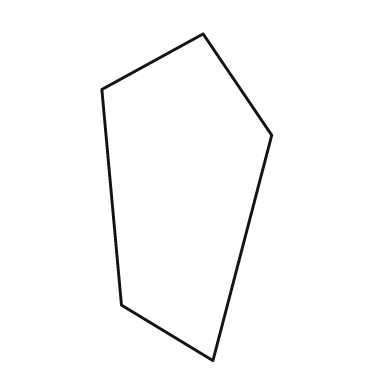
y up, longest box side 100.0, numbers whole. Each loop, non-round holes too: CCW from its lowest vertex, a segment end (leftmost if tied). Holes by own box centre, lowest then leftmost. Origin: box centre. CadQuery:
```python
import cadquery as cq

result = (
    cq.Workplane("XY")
    .moveTo(8.0, -50.0)
    .lineTo(26.0, 19.0)
    .lineTo(5.0, 50.0)
    .lineTo(-26.0, 33.0)
    .lineTo(-20.0, -33.0)
    .close()
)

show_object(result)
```